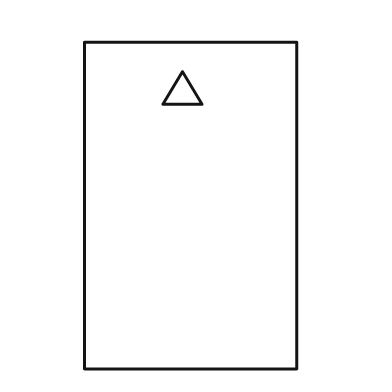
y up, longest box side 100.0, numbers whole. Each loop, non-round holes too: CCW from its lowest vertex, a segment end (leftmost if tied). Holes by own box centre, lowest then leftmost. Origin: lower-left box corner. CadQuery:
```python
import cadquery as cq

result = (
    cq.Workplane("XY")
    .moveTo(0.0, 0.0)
    .lineTo(65.0, 0.0)
    .lineTo(65.0, 100.0)
    .lineTo(0.0, 100.0)
    .close()
    .moveTo(24.0, 81.0)
    .lineTo(36.0, 81.0)
    .lineTo(30.0, 91.0)
    .close()
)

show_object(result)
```